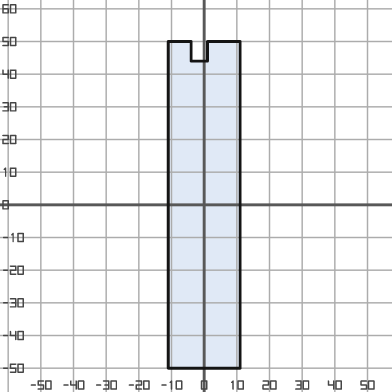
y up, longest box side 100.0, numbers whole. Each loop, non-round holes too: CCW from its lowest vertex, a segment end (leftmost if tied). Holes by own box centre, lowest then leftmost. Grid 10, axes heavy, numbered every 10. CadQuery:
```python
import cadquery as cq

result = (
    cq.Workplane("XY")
    .moveTo(-11.0, -50.0)
    .lineTo(11.0, -50.0)
    .lineTo(11.0, 50.0)
    .lineTo(1.0, 50.0)
    .lineTo(1.0, 44.0)
    .lineTo(-4.0, 44.0)
    .lineTo(-4.0, 50.0)
    .lineTo(-11.0, 50.0)
    .close()
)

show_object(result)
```